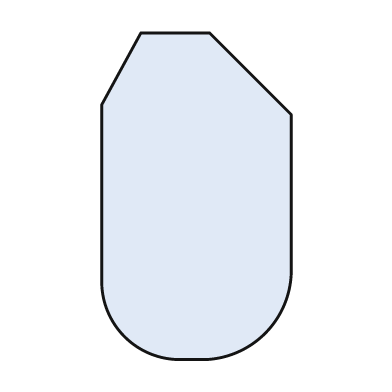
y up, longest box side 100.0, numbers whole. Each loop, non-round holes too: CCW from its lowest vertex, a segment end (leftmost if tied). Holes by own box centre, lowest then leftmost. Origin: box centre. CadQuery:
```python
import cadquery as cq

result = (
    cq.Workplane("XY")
    .moveTo(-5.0, -50.0)
    .lineTo(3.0, -50.0)
    .threePointArc((21.0, -42.0), (29.0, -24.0))
    .lineTo(29.0, 25.0)
    .lineTo(4.0, 50.0)
    .lineTo(-17.0, 50.0)
    .lineTo(-29.0, 28.0)
    .lineTo(-29.0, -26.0)
    .threePointArc((-22.0, -43.0), (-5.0, -50.0))
    .close()
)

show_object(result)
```